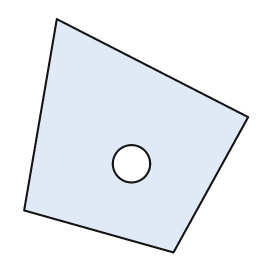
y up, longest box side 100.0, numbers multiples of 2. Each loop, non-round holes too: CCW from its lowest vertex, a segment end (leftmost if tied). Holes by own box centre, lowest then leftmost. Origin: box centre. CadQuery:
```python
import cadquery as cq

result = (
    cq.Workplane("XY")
    .moveTo(16.0, -50.0)
    .lineTo(48.0, 8.0)
    .lineTo(-34.0, 50.0)
    .lineTo(-48.0, -32.0)
    .close()
    .moveTo(-2.0, -12.0)
    .circle(8.0)
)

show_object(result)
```